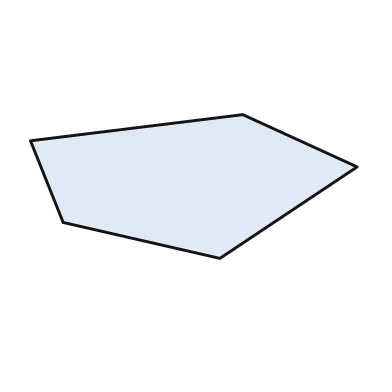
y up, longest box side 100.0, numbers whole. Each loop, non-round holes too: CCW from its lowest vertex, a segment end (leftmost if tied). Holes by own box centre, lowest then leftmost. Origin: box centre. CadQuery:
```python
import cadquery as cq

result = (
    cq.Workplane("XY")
    .moveTo(8.0, -22.0)
    .lineTo(50.0, 6.0)
    .lineTo(15.0, 22.0)
    .lineTo(-50.0, 14.0)
    .lineTo(-40.0, -11.0)
    .close()
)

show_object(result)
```